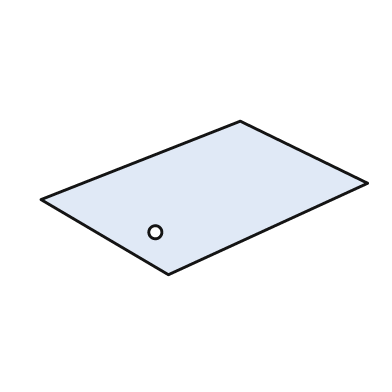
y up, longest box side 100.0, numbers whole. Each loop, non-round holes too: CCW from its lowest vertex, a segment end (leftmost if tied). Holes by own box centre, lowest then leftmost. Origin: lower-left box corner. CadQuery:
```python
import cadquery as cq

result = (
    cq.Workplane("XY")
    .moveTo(39.0, 0.0)
    .lineTo(100.0, 28.0)
    .lineTo(61.0, 47.0)
    .lineTo(0.0, 23.0)
    .close()
    .moveTo(35.0, 13.0)
    .circle(2.0)
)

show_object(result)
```